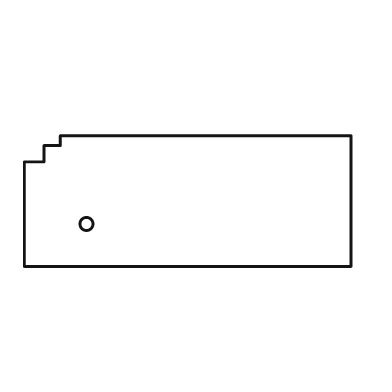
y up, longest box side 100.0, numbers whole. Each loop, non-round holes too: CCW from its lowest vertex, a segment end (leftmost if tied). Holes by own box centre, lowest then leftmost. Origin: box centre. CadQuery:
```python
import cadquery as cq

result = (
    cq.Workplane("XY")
    .moveTo(-50.0, -20.0)
    .lineTo(50.0, -20.0)
    .lineTo(50.0, 20.0)
    .lineTo(-39.0, 20.0)
    .lineTo(-39.0, 17.0)
    .lineTo(-44.0, 17.0)
    .lineTo(-44.0, 12.0)
    .lineTo(-50.0, 12.0)
    .close()
    .moveTo(-31.0, -7.0)
    .circle(2.0)
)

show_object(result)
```